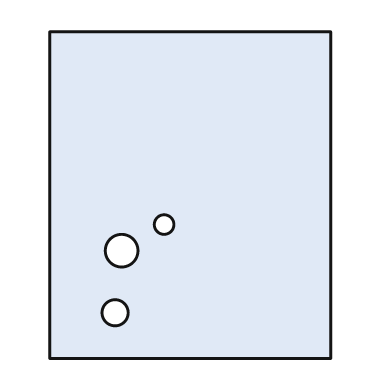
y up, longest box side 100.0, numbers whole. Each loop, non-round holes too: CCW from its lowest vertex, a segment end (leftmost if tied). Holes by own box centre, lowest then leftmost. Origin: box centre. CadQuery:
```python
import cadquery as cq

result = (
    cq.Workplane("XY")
    .moveTo(-43.0, -50.0)
    .lineTo(43.0, -50.0)
    .lineTo(43.0, 50.0)
    .lineTo(-43.0, 50.0)
    .close()
    .moveTo(-23.0, -36.0)
    .circle(4.0)
    .moveTo(-21.0, -17.0)
    .circle(5.0)
    .moveTo(-8.0, -9.0)
    .circle(3.0)
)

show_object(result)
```